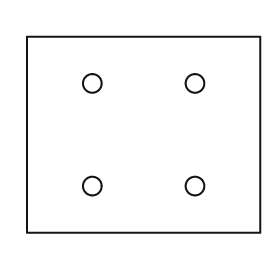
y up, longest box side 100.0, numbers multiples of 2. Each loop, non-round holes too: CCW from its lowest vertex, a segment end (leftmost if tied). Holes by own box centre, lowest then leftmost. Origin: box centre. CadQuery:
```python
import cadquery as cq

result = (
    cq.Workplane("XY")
    .moveTo(-50.0, -42.0)
    .lineTo(50.0, -42.0)
    .lineTo(50.0, 42.0)
    .lineTo(-50.0, 42.0)
    .close()
    .moveTo(-22.0, -22.0)
    .circle(4.0)
    .moveTo(22.0, -22.0)
    .circle(4.0)
    .moveTo(-22.0, 22.0)
    .circle(4.0)
    .moveTo(22.0, 22.0)
    .circle(4.0)
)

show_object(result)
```